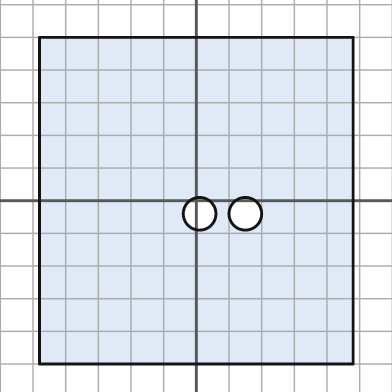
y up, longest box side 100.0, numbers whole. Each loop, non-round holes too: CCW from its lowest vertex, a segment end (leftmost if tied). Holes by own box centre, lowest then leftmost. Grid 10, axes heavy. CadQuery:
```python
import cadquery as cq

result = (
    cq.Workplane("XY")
    .moveTo(-48.0, -50.0)
    .lineTo(48.0, -50.0)
    .lineTo(48.0, 50.0)
    .lineTo(-48.0, 50.0)
    .close()
    .moveTo(1.0, -4.0)
    .circle(5.0)
    .moveTo(15.0, -4.0)
    .circle(5.0)
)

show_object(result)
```